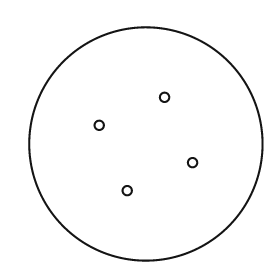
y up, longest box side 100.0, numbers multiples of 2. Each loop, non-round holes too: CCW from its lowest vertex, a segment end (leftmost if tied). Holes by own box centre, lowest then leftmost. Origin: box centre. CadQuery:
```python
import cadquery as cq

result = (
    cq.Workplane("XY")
    .moveTo(0.0, 0.0)
    .circle(50.0)
    .moveTo(-8.0, -20.0)
    .circle(2.0)
    .moveTo(20.0, -8.0)
    .circle(2.0)
    .moveTo(-20.0, 8.0)
    .circle(2.0)
    .moveTo(8.0, 20.0)
    .circle(2.0)
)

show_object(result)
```